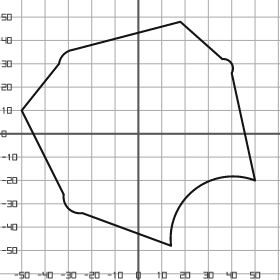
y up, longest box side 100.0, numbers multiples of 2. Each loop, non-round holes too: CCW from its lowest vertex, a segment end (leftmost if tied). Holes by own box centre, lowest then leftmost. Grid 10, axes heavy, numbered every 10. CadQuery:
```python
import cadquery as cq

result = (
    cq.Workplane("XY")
    .moveTo(14.0, -48.0)
    .threePointArc((24.0, -24.0), (50.0, -20.0))
    .lineTo(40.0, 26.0)
    .threePointArc((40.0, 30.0), (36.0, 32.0))
    .lineTo(18.0, 48.0)
    .lineTo(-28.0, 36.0)
    .threePointArc((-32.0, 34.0), (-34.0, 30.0))
    .lineTo(-50.0, 10.0)
    .lineTo(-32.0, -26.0)
    .threePointArc((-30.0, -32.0), (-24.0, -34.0))
    .close()
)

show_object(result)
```